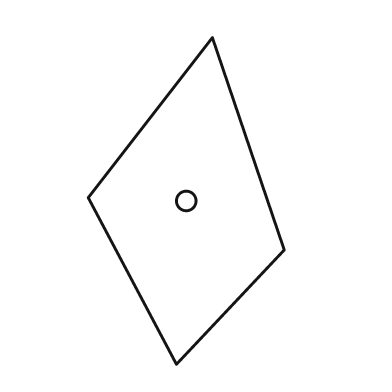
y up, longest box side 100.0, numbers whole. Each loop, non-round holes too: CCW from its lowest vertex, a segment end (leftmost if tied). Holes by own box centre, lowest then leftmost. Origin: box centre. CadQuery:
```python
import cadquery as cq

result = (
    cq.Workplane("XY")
    .moveTo(-3.0, -50.0)
    .lineTo(30.0, -15.0)
    .lineTo(8.0, 50.0)
    .lineTo(-30.0, 1.0)
    .close()
    .moveTo(0.0, 0.0)
    .circle(3.0)
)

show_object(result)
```